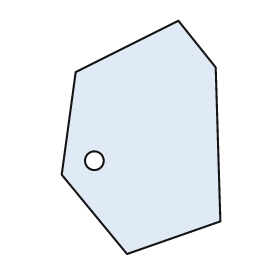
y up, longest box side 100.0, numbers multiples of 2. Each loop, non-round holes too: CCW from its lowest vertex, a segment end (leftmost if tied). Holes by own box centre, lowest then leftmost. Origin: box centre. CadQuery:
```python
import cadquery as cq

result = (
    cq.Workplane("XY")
    .moveTo(-6.0, -50.0)
    .lineTo(34.0, -36.0)
    .lineTo(32.0, 30.0)
    .lineTo(16.0, 50.0)
    .lineTo(-28.0, 28.0)
    .lineTo(-34.0, -16.0)
    .close()
    .moveTo(-20.0, -10.0)
    .circle(4.0)
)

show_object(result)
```